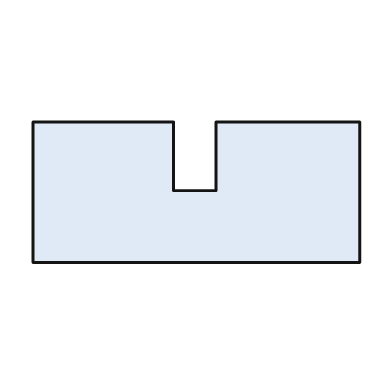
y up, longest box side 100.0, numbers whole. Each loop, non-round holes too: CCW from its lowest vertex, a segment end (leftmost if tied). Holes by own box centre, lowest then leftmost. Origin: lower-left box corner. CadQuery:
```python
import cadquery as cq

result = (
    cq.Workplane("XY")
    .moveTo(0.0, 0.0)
    .lineTo(100.0, 0.0)
    .lineTo(100.0, 43.0)
    .lineTo(56.0, 43.0)
    .lineTo(56.0, 22.0)
    .lineTo(43.0, 22.0)
    .lineTo(43.0, 43.0)
    .lineTo(0.0, 43.0)
    .close()
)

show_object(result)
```